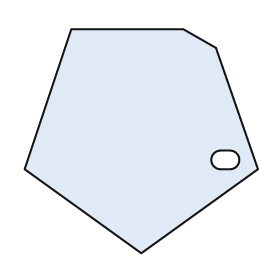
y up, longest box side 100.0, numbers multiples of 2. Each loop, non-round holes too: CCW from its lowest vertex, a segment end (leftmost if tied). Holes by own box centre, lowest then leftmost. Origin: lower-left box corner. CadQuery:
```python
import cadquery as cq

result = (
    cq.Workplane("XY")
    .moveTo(50.0, 0.0)
    .lineTo(100.0, 36.0)
    .lineTo(82.0, 88.0)
    .lineTo(68.0, 96.0)
    .lineTo(20.0, 96.0)
    .lineTo(0.0, 36.0)
    .close()
    .moveTo(84.0, 36.0)
    .lineTo(88.0, 36.0)
    .threePointArc((92.0, 40.0), (88.0, 44.0))
    .lineTo(84.0, 44.0)
    .threePointArc((80.0, 40.0), (84.0, 36.0))
    .close()
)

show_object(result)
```